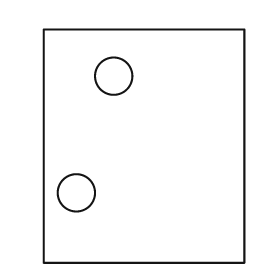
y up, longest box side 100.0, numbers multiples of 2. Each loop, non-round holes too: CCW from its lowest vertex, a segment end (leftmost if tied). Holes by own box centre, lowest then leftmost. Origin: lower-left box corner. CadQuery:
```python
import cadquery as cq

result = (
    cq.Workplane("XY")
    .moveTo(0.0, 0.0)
    .lineTo(86.0, 0.0)
    .lineTo(86.0, 100.0)
    .lineTo(0.0, 100.0)
    .close()
    .moveTo(14.0, 30.0)
    .circle(8.0)
    .moveTo(30.0, 80.0)
    .circle(8.0)
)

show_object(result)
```